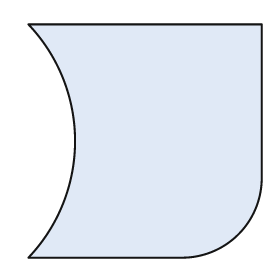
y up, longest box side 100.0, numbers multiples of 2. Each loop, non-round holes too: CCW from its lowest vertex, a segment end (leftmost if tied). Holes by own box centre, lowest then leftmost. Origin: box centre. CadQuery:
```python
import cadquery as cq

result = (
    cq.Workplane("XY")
    .moveTo(-50.0, -50.0)
    .lineTo(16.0, -50.0)
    .threePointArc((40.0, -40.0), (50.0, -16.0))
    .lineTo(50.0, 50.0)
    .lineTo(-50.0, 50.0)
    .threePointArc((-30.0, 0.0), (-50.0, -50.0))
    .close()
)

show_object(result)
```